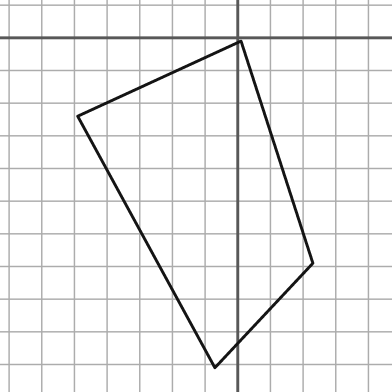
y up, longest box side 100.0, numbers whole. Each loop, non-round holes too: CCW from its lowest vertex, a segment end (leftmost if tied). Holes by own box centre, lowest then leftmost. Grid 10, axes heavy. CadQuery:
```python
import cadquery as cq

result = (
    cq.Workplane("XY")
    .moveTo(-7.0, -101.0)
    .lineTo(23.0, -69.0)
    .lineTo(1.0, -1.0)
    .lineTo(-49.0, -24.0)
    .close()
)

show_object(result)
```